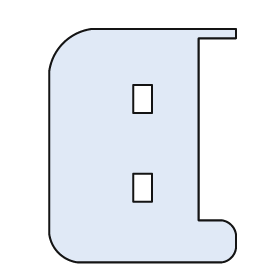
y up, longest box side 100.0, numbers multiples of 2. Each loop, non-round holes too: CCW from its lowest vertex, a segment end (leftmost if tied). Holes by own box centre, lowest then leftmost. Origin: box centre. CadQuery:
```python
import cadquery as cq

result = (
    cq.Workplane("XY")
    .moveTo(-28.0, -50.0)
    .lineTo(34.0, -50.0)
    .threePointArc((38.0, -48.0), (40.0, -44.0))
    .lineTo(40.0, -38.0)
    .threePointArc((38.0, -34.0), (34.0, -32.0))
    .lineTo(24.0, -32.0)
    .lineTo(24.0, 46.0)
    .lineTo(40.0, 46.0)
    .lineTo(40.0, 50.0)
    .lineTo(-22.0, 50.0)
    .threePointArc((-34.0, 44.0), (-40.0, 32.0))
    .lineTo(-40.0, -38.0)
    .threePointArc((-36.0, -46.0), (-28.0, -50.0))
    .close()
    .moveTo(-4.0, -24.0)
    .lineTo(4.0, -24.0)
    .lineTo(4.0, -12.0)
    .lineTo(-4.0, -12.0)
    .close()
    .moveTo(-4.0, 14.0)
    .lineTo(4.0, 14.0)
    .lineTo(4.0, 26.0)
    .lineTo(-4.0, 26.0)
    .close()
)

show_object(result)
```